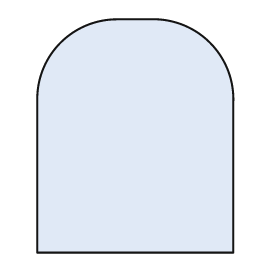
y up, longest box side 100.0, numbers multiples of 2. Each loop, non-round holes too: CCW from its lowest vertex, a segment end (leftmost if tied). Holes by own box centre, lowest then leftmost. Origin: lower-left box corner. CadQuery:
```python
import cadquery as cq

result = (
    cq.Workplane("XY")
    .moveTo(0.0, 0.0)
    .lineTo(84.0, 0.0)
    .lineTo(84.0, 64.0)
    .threePointArc((74.0, 90.0), (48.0, 100.0))
    .lineTo(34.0, 100.0)
    .threePointArc((10.0, 90.0), (0.0, 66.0))
    .close()
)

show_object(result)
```